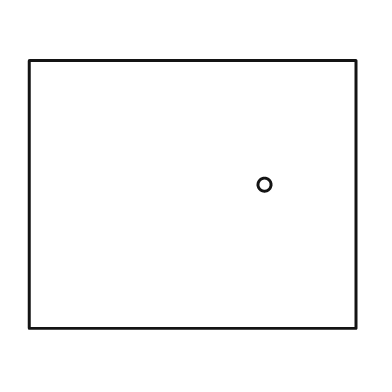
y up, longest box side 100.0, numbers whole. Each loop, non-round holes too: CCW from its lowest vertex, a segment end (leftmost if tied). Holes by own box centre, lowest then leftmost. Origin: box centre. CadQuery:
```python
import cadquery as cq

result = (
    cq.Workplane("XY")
    .moveTo(-50.0, -41.0)
    .lineTo(50.0, -41.0)
    .lineTo(50.0, 41.0)
    .lineTo(-50.0, 41.0)
    .close()
    .moveTo(22.0, 3.0)
    .circle(2.0)
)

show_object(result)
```